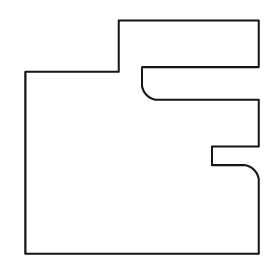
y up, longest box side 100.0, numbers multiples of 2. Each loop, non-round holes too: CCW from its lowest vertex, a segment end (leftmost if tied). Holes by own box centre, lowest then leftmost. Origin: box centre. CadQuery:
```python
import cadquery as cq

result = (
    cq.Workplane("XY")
    .moveTo(-50.0, -50.0)
    .lineTo(50.0, -50.0)
    .lineTo(50.0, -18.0)
    .threePointArc((48.0, -14.0), (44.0, -12.0))
    .lineTo(30.0, -12.0)
    .lineTo(30.0, -4.0)
    .lineTo(50.0, -4.0)
    .lineTo(50.0, 16.0)
    .lineTo(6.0, 16.0)
    .threePointArc((2.0, 18.0), (0.0, 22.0))
    .lineTo(0.0, 30.0)
    .lineTo(50.0, 30.0)
    .lineTo(50.0, 50.0)
    .lineTo(-10.0, 50.0)
    .lineTo(-10.0, 28.0)
    .lineTo(-50.0, 28.0)
    .close()
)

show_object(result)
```